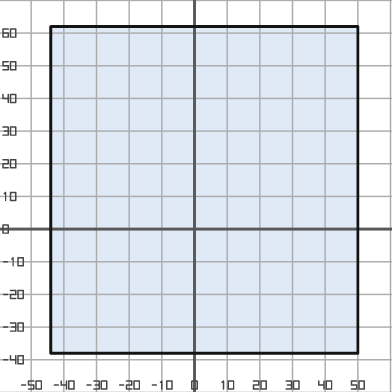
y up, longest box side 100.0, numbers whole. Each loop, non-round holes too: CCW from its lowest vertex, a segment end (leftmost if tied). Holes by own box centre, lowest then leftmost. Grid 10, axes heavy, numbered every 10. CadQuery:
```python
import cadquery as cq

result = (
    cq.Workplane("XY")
    .moveTo(-44.0, -38.0)
    .lineTo(50.0, -38.0)
    .lineTo(50.0, 62.0)
    .lineTo(-44.0, 62.0)
    .close()
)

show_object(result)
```